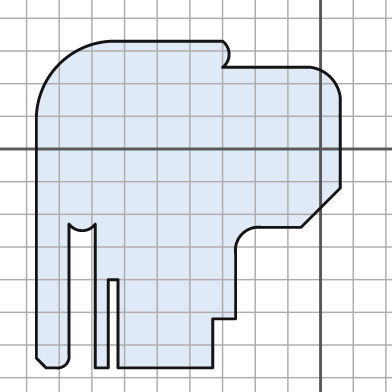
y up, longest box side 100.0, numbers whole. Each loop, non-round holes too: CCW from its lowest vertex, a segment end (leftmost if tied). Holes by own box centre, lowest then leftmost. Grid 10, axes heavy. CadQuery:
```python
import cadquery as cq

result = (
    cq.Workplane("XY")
    .moveTo(-84.0, -67.0)
    .lineTo(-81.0, -67.0)
    .threePointArc((-78.0, -66.0), (-77.0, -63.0))
    .lineTo(-77.0, -23.0)
    .threePointArc((-73.0, -25.0), (-69.0, -23.0))
    .lineTo(-69.0, -67.0)
    .lineTo(-65.0, -67.0)
    .lineTo(-65.0, -40.0)
    .lineTo(-62.0, -40.0)
    .lineTo(-62.0, -67.0)
    .lineTo(-33.0, -67.0)
    .lineTo(-33.0, -52.0)
    .lineTo(-26.0, -52.0)
    .lineTo(-26.0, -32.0)
    .threePointArc((-24.0, -26.0), (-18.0, -24.0))
    .lineTo(-6.0, -24.0)
    .lineTo(6.0, -12.0)
    .lineTo(6.0, 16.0)
    .threePointArc((3.0, 22.0), (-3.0, 25.0))
    .lineTo(-30.0, 25.0)
    .threePointArc((-28.0, 29.0), (-30.0, 33.0))
    .lineTo(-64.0, 33.0)
    .threePointArc((-80.0, 26.0), (-87.0, 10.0))
    .lineTo(-87.0, -64.0)
    .close()
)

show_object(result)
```